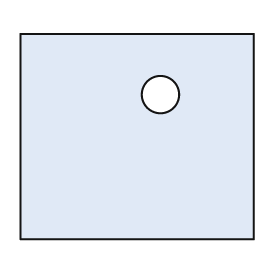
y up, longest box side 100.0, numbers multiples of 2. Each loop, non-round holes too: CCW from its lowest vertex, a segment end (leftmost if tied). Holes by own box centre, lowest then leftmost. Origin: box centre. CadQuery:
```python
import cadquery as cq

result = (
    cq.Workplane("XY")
    .moveTo(-50.0, -44.0)
    .lineTo(50.0, -44.0)
    .lineTo(50.0, 44.0)
    .lineTo(-50.0, 44.0)
    .close()
    .moveTo(10.0, 18.0)
    .circle(8.0)
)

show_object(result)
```